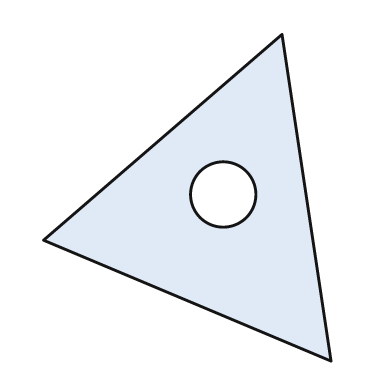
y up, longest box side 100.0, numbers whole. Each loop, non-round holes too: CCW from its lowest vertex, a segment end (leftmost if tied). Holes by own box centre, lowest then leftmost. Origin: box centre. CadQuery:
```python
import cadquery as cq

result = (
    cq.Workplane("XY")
    .moveTo(44.0, -50.0)
    .lineTo(29.0, 50.0)
    .lineTo(-44.0, -13.0)
    .close()
    .moveTo(11.0, 1.0)
    .circle(10.0)
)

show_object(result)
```